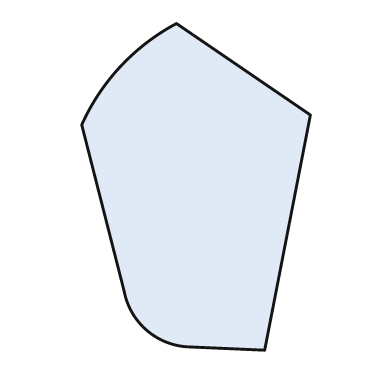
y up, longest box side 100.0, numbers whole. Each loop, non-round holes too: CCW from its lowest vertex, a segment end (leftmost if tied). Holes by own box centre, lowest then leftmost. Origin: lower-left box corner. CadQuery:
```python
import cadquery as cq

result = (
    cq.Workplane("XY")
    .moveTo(56.0, 0.0)
    .lineTo(70.0, 72.0)
    .lineTo(29.0, 100.0)
    .threePointArc((12.0, 87.0), (0.0, 69.0))
    .lineTo(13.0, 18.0)
    .threePointArc((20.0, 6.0), (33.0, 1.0))
    .close()
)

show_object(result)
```